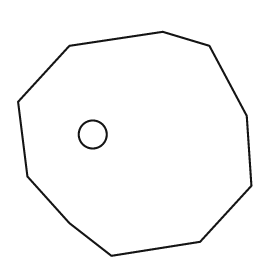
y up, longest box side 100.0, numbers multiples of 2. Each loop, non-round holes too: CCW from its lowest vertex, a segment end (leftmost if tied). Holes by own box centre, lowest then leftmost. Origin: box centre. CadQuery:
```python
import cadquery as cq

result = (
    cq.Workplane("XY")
    .moveTo(-10.0, -48.0)
    .lineTo(28.0, -42.0)
    .lineTo(50.0, -18.0)
    .lineTo(48.0, 12.0)
    .lineTo(32.0, 42.0)
    .lineTo(12.0, 48.0)
    .lineTo(-28.0, 42.0)
    .lineTo(-50.0, 18.0)
    .lineTo(-46.0, -14.0)
    .lineTo(-28.0, -34.0)
    .close()
    .moveTo(-18.0, 4.0)
    .circle(6.0)
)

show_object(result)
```